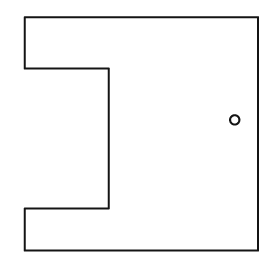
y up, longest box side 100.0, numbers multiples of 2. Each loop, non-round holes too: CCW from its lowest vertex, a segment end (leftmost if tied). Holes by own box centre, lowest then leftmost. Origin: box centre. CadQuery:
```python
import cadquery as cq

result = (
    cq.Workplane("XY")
    .moveTo(-50.0, -50.0)
    .lineTo(50.0, -50.0)
    .lineTo(50.0, 50.0)
    .lineTo(-50.0, 50.0)
    .lineTo(-50.0, 28.0)
    .lineTo(-14.0, 28.0)
    .lineTo(-14.0, -32.0)
    .lineTo(-50.0, -32.0)
    .close()
    .moveTo(40.0, 6.0)
    .circle(2.0)
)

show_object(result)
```